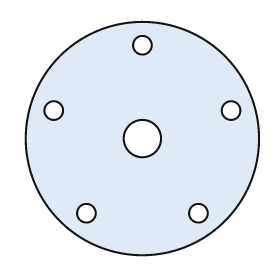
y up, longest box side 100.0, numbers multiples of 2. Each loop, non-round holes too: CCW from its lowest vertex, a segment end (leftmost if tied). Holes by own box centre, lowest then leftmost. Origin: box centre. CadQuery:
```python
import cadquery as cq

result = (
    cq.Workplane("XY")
    .moveTo(0.0, 0.0)
    .circle(50.0)
    .moveTo(-24.0, -32.0)
    .circle(4.0)
    .moveTo(24.0, -32.0)
    .circle(4.0)
    .moveTo(0.0, 0.0)
    .circle(8.0)
    .moveTo(-38.0, 12.0)
    .circle(4.0)
    .moveTo(38.0, 12.0)
    .circle(4.0)
    .moveTo(0.0, 40.0)
    .circle(4.0)
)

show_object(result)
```